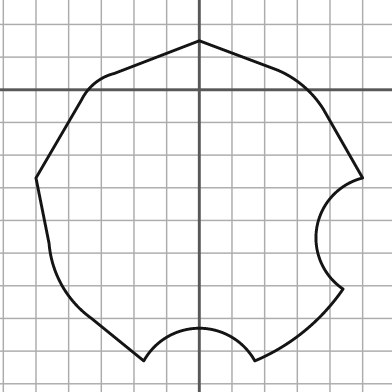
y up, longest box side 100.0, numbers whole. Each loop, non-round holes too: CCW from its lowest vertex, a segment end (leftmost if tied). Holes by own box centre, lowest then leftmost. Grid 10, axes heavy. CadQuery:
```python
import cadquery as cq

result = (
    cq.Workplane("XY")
    .moveTo(-17.0, -83.0)
    .threePointArc((0.0, -73.0), (17.0, -83.0))
    .threePointArc((32.0, -74.0), (44.0, -61.0))
    .threePointArc((36.0, -42.0), (50.0, -27.0))
    .lineTo(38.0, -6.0)
    .threePointArc((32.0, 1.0), (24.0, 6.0))
    .lineTo(0.0, 15.0)
    .lineTo(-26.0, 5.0)
    .threePointArc((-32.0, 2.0), (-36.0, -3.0))
    .lineTo(-50.0, -27.0)
    .lineTo(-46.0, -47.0)
    .threePointArc((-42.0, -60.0), (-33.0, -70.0))
    .close()
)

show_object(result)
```